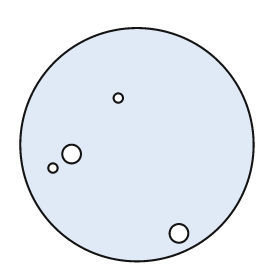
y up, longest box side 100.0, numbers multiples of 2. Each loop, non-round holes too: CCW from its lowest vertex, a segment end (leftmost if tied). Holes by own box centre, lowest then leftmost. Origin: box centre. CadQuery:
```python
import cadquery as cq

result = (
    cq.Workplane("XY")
    .moveTo(0.0, 0.0)
    .circle(50.0)
    .moveTo(18.0, -38.0)
    .circle(4.0)
    .moveTo(-36.0, -10.0)
    .circle(2.0)
    .moveTo(-28.0, -4.0)
    .circle(4.0)
    .moveTo(-8.0, 20.0)
    .circle(2.0)
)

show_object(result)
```